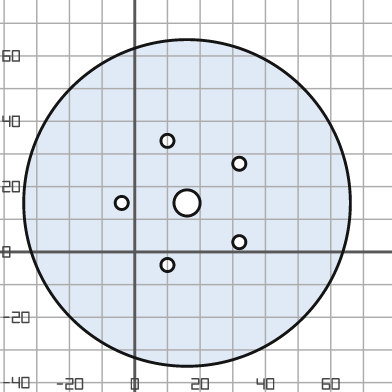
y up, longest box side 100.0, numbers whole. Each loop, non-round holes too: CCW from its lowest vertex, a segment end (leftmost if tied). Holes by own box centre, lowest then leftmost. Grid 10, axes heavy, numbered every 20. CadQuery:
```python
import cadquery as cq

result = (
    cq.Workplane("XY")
    .moveTo(16.0, 15.0)
    .circle(50.0)
    .moveTo(10.0, -4.0)
    .circle(2.0)
    .moveTo(32.0, 3.0)
    .circle(2.0)
    .moveTo(-4.0, 15.0)
    .circle(2.0)
    .moveTo(16.0, 15.0)
    .circle(4.0)
    .moveTo(32.0, 27.0)
    .circle(2.0)
    .moveTo(10.0, 34.0)
    .circle(2.0)
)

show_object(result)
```